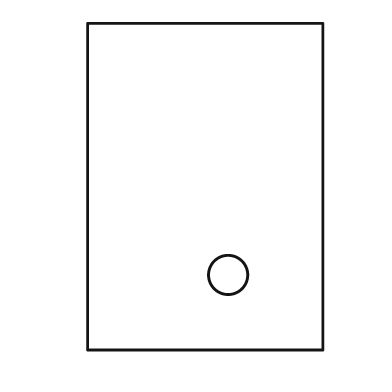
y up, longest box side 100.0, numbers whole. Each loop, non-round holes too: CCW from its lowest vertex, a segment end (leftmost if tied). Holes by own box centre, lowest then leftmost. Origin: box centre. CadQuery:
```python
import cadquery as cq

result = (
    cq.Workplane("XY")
    .moveTo(-36.0, -50.0)
    .lineTo(36.0, -50.0)
    .lineTo(36.0, 50.0)
    .lineTo(-36.0, 50.0)
    .close()
    .moveTo(7.0, -27.0)
    .circle(6.0)
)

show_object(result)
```